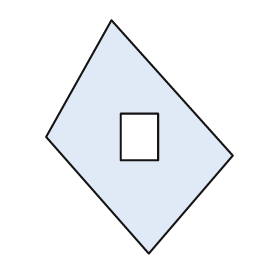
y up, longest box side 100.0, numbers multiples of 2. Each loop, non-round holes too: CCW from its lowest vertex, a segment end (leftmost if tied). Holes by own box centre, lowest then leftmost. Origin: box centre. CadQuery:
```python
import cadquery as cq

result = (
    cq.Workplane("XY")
    .moveTo(4.0, -50.0)
    .lineTo(40.0, -8.0)
    .lineTo(-12.0, 50.0)
    .lineTo(-40.0, 0.0)
    .close()
    .moveTo(-8.0, -10.0)
    .lineTo(8.0, -10.0)
    .lineTo(8.0, 10.0)
    .lineTo(-8.0, 10.0)
    .close()
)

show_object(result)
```